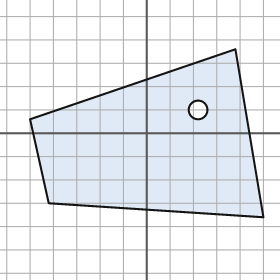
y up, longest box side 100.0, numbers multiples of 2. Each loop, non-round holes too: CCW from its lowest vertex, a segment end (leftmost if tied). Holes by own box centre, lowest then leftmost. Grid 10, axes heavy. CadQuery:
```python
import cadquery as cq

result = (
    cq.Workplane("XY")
    .moveTo(50.0, -36.0)
    .lineTo(38.0, 36.0)
    .lineTo(-50.0, 6.0)
    .lineTo(-42.0, -30.0)
    .close()
    .moveTo(22.0, 10.0)
    .circle(4.0)
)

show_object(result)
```